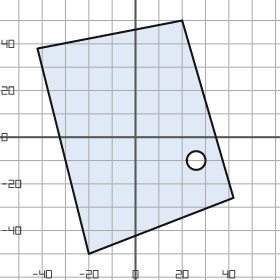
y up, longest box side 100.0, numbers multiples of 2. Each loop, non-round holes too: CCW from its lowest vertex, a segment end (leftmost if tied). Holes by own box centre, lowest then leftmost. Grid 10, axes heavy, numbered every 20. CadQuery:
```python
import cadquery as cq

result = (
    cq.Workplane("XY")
    .moveTo(-20.0, -50.0)
    .lineTo(42.0, -26.0)
    .lineTo(20.0, 50.0)
    .lineTo(-42.0, 38.0)
    .close()
    .moveTo(26.0, -10.0)
    .circle(4.0)
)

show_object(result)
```